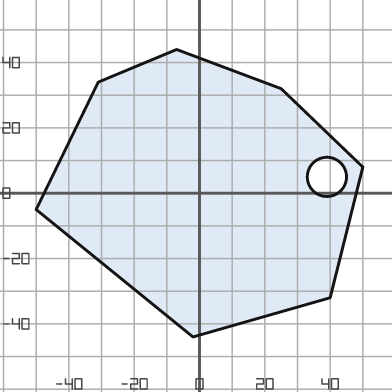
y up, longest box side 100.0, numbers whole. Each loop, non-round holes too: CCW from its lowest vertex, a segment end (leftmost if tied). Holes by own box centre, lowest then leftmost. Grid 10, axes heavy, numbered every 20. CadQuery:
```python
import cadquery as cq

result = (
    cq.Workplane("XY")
    .moveTo(-2.0, -44.0)
    .lineTo(40.0, -32.0)
    .lineTo(50.0, 8.0)
    .lineTo(25.0, 32.0)
    .lineTo(-7.0, 44.0)
    .lineTo(-31.0, 34.0)
    .lineTo(-50.0, -5.0)
    .close()
    .moveTo(39.0, 5.0)
    .circle(6.0)
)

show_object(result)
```